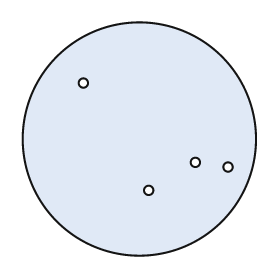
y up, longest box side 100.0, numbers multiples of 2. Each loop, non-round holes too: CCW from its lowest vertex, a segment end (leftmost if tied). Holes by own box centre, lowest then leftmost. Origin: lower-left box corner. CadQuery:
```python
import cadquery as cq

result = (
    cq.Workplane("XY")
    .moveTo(50.0, 50.0)
    .circle(50.0)
    .moveTo(54.0, 28.0)
    .circle(2.0)
    .moveTo(88.0, 38.0)
    .circle(2.0)
    .moveTo(74.0, 40.0)
    .circle(2.0)
    .moveTo(26.0, 74.0)
    .circle(2.0)
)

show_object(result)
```